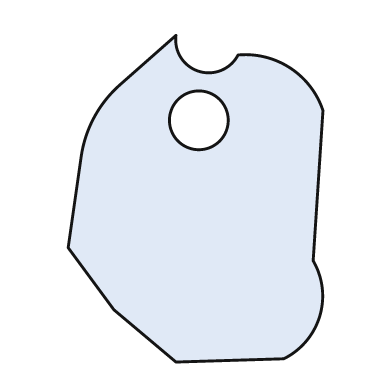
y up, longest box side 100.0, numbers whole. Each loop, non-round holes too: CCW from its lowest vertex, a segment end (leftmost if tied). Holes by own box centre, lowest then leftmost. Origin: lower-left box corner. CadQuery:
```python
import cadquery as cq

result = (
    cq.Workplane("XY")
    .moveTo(33.0, 0.0)
    .lineTo(66.0, 1.0)
    .threePointArc((77.0, 14.0), (75.0, 31.0))
    .lineTo(78.0, 77.0)
    .threePointArc((68.0, 90.0), (52.0, 94.0))
    .threePointArc((40.0, 89.0), (33.0, 100.0))
    .lineTo(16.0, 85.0)
    .threePointArc((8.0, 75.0), (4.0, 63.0))
    .lineTo(0.0, 35.0)
    .lineTo(14.0, 16.0)
    .close()
    .moveTo(40.0, 74.0)
    .circle(9.0)
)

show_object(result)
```